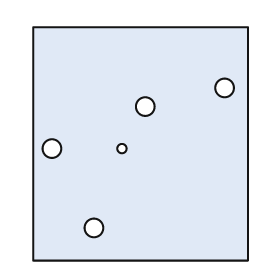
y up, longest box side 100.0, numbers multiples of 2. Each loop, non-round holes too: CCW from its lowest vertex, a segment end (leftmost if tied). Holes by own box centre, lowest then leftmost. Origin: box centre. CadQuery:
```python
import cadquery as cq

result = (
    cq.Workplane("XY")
    .moveTo(-46.0, -50.0)
    .lineTo(46.0, -50.0)
    .lineTo(46.0, 50.0)
    .lineTo(-46.0, 50.0)
    .close()
    .moveTo(-20.0, -36.0)
    .circle(4.0)
    .moveTo(-38.0, -2.0)
    .circle(4.0)
    .moveTo(-8.0, -2.0)
    .circle(2.0)
    .moveTo(2.0, 16.0)
    .circle(4.0)
    .moveTo(36.0, 24.0)
    .circle(4.0)
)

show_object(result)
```